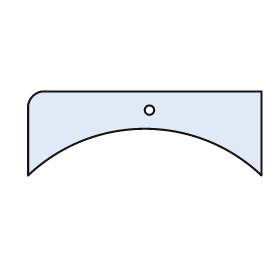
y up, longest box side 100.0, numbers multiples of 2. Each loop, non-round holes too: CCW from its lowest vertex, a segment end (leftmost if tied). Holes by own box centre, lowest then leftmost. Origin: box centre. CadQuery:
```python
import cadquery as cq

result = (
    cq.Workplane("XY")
    .moveTo(-50.0, -18.0)
    .threePointArc((0.0, 2.0), (50.0, -18.0))
    .lineTo(50.0, 18.0)
    .lineTo(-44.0, 18.0)
    .threePointArc((-48.0, 16.0), (-50.0, 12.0))
    .close()
    .moveTo(2.0, 10.0)
    .circle(2.0)
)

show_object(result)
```